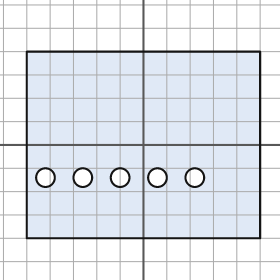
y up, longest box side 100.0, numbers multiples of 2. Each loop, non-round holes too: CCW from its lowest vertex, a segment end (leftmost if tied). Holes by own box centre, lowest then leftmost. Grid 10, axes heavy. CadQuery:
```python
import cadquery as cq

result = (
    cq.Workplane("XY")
    .moveTo(-50.0, -40.0)
    .lineTo(50.0, -40.0)
    .lineTo(50.0, 40.0)
    .lineTo(-50.0, 40.0)
    .close()
    .moveTo(-42.0, -14.0)
    .circle(4.0)
    .moveTo(-26.0, -14.0)
    .circle(4.0)
    .moveTo(-10.0, -14.0)
    .circle(4.0)
    .moveTo(6.0, -14.0)
    .circle(4.0)
    .moveTo(22.0, -14.0)
    .circle(4.0)
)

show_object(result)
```